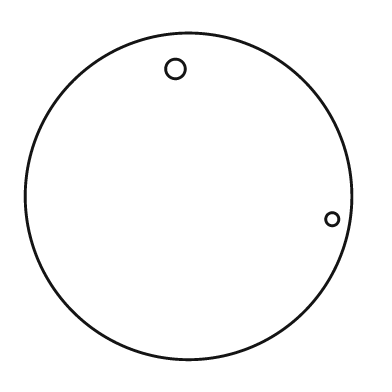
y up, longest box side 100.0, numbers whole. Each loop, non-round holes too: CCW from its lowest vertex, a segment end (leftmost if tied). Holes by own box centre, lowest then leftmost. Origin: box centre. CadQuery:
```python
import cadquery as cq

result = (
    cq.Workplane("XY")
    .moveTo(0.0, 0.0)
    .circle(50.0)
    .moveTo(44.0, -7.0)
    .circle(2.0)
    .moveTo(-4.0, 39.0)
    .circle(3.0)
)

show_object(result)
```